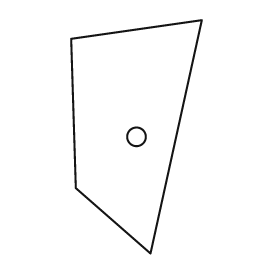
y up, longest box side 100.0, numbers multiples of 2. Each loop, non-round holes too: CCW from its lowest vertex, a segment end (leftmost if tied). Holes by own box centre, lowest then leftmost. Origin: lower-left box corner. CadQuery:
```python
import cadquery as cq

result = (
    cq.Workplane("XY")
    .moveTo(34.0, 0.0)
    .lineTo(56.0, 100.0)
    .lineTo(0.0, 92.0)
    .lineTo(2.0, 28.0)
    .close()
    .moveTo(28.0, 50.0)
    .circle(4.0)
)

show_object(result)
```